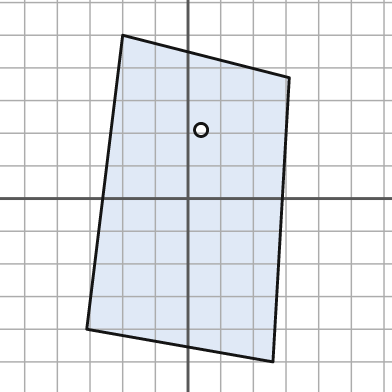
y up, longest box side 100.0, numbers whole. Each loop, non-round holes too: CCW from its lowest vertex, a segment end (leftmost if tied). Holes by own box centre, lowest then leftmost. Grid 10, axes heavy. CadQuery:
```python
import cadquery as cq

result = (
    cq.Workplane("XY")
    .moveTo(26.0, -50.0)
    .lineTo(31.0, 37.0)
    .lineTo(-20.0, 50.0)
    .lineTo(-31.0, -40.0)
    .close()
    .moveTo(4.0, 21.0)
    .circle(2.0)
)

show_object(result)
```